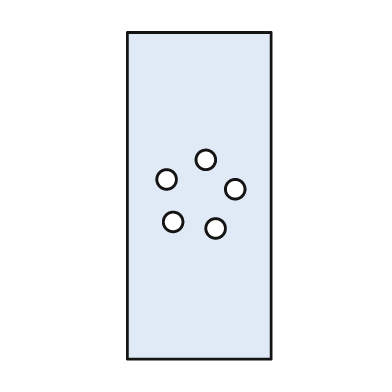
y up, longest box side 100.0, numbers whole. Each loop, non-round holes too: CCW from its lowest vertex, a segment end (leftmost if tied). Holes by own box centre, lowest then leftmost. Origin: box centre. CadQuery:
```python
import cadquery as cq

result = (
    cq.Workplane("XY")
    .moveTo(-22.0, -50.0)
    .lineTo(22.0, -50.0)
    .lineTo(22.0, 50.0)
    .lineTo(-22.0, 50.0)
    .close()
    .moveTo(5.0, -10.0)
    .circle(3.0)
    .moveTo(-8.0, -8.0)
    .circle(3.0)
    .moveTo(11.0, 2.0)
    .circle(3.0)
    .moveTo(-10.0, 5.0)
    .circle(3.0)
    .moveTo(2.0, 11.0)
    .circle(3.0)
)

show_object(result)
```